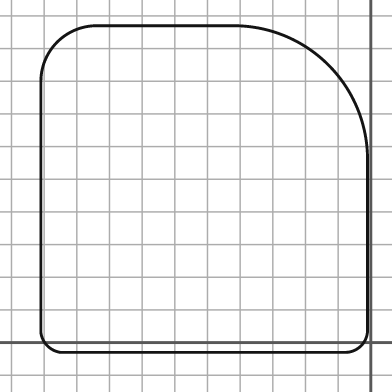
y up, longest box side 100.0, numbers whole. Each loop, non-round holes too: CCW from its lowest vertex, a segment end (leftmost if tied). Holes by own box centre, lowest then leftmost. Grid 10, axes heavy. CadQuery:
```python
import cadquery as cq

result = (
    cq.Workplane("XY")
    .moveTo(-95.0, -3.0)
    .lineTo(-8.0, -3.0)
    .threePointArc((-3.0, -1.0), (-1.0, 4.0))
    .lineTo(-1.0, 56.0)
    .threePointArc((-13.0, 85.0), (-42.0, 97.0))
    .lineTo(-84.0, 97.0)
    .threePointArc((-96.0, 92.0), (-101.0, 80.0))
    .lineTo(-101.0, 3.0)
    .threePointArc((-99.0, -1.0), (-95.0, -3.0))
    .close()
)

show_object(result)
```